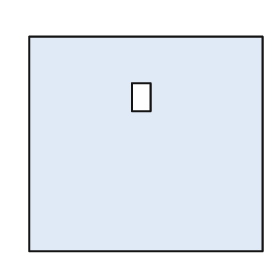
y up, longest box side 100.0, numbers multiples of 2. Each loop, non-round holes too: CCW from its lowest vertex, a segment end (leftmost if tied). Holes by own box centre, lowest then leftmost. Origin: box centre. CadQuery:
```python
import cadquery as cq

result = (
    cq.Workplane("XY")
    .moveTo(-50.0, -46.0)
    .lineTo(50.0, -46.0)
    .lineTo(50.0, 46.0)
    .lineTo(-50.0, 46.0)
    .close()
    .moveTo(-6.0, 14.0)
    .lineTo(2.0, 14.0)
    .lineTo(2.0, 26.0)
    .lineTo(-6.0, 26.0)
    .close()
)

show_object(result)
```